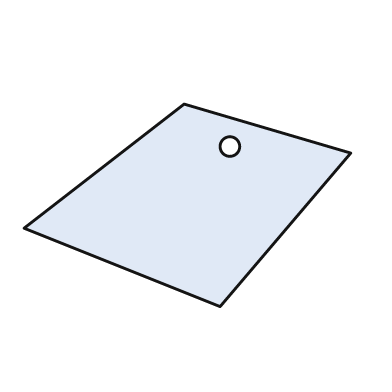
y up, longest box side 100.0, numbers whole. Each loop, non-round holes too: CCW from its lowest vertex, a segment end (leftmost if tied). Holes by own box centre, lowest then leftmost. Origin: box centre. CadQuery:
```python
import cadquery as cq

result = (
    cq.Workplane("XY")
    .moveTo(10.0, -31.0)
    .lineTo(50.0, 16.0)
    .lineTo(-1.0, 31.0)
    .lineTo(-50.0, -7.0)
    .close()
    .moveTo(13.0, 18.0)
    .circle(3.0)
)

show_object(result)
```